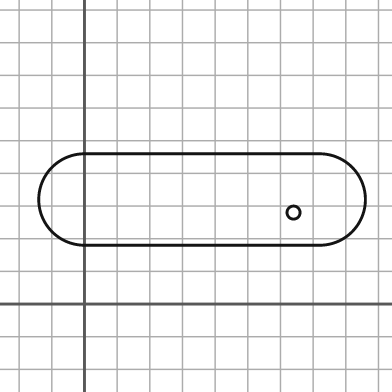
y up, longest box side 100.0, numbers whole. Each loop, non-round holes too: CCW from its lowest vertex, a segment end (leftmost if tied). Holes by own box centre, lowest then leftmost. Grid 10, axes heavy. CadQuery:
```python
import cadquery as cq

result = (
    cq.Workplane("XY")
    .moveTo(0.0, 18.0)
    .lineTo(72.0, 18.0)
    .threePointArc((86.0, 32.0), (72.0, 46.0))
    .lineTo(0.0, 46.0)
    .threePointArc((-14.0, 32.0), (0.0, 18.0))
    .close()
    .moveTo(64.0, 28.0)
    .circle(2.0)
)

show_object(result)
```